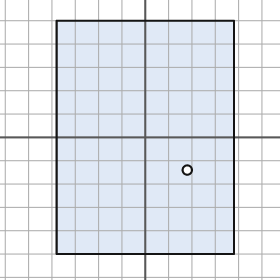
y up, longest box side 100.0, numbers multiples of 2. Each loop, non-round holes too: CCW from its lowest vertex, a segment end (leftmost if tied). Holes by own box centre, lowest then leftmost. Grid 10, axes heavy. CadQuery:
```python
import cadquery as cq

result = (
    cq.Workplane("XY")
    .moveTo(-38.0, -50.0)
    .lineTo(38.0, -50.0)
    .lineTo(38.0, 50.0)
    .lineTo(-38.0, 50.0)
    .close()
    .moveTo(18.0, -14.0)
    .circle(2.0)
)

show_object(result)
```